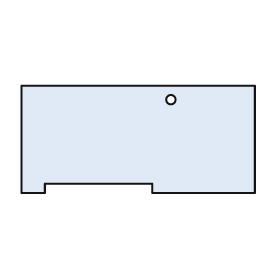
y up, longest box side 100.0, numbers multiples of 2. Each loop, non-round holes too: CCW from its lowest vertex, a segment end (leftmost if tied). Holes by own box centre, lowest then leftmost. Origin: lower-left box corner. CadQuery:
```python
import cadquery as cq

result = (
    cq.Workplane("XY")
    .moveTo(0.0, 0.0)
    .lineTo(10.0, 0.0)
    .lineTo(10.0, 4.0)
    .lineTo(56.0, 4.0)
    .lineTo(56.0, 0.0)
    .lineTo(100.0, 0.0)
    .lineTo(100.0, 46.0)
    .lineTo(0.0, 46.0)
    .close()
    .moveTo(64.0, 40.0)
    .circle(2.0)
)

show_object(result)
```